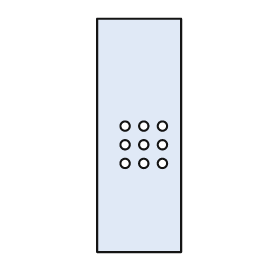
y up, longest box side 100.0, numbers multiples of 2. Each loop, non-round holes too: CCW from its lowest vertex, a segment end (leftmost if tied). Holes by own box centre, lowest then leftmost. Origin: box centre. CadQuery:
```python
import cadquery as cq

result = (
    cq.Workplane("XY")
    .moveTo(-18.0, -50.0)
    .lineTo(18.0, -50.0)
    .lineTo(18.0, 50.0)
    .lineTo(-18.0, 50.0)
    .close()
    .moveTo(-6.0, -12.0)
    .circle(2.0)
    .moveTo(2.0, -12.0)
    .circle(2.0)
    .moveTo(10.0, -12.0)
    .circle(2.0)
    .moveTo(-6.0, -4.0)
    .circle(2.0)
    .moveTo(2.0, -4.0)
    .circle(2.0)
    .moveTo(10.0, -4.0)
    .circle(2.0)
    .moveTo(-6.0, 4.0)
    .circle(2.0)
    .moveTo(2.0, 4.0)
    .circle(2.0)
    .moveTo(10.0, 4.0)
    .circle(2.0)
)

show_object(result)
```